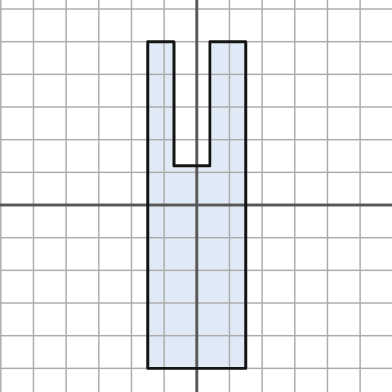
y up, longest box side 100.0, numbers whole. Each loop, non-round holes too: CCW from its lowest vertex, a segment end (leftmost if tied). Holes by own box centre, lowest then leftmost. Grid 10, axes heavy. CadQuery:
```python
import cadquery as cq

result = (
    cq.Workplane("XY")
    .moveTo(-15.0, -50.0)
    .lineTo(15.0, -50.0)
    .lineTo(15.0, 50.0)
    .lineTo(4.0, 50.0)
    .lineTo(4.0, 12.0)
    .lineTo(-7.0, 12.0)
    .lineTo(-7.0, 50.0)
    .lineTo(-15.0, 50.0)
    .close()
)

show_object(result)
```